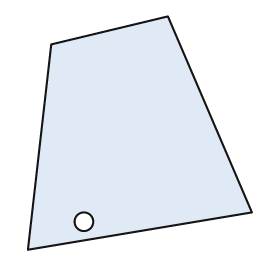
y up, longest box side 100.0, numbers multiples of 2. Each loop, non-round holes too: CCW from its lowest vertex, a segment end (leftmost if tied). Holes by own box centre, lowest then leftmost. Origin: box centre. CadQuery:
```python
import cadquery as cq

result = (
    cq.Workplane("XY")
    .moveTo(-48.0, -50.0)
    .lineTo(48.0, -34.0)
    .lineTo(12.0, 50.0)
    .lineTo(-38.0, 38.0)
    .close()
    .moveTo(-24.0, -38.0)
    .circle(4.0)
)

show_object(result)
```